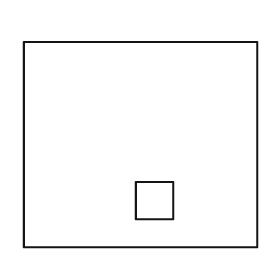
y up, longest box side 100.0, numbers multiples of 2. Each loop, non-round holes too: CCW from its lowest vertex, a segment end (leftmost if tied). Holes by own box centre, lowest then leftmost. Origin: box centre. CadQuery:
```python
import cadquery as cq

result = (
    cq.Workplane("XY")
    .moveTo(-50.0, -44.0)
    .lineTo(50.0, -44.0)
    .lineTo(50.0, 44.0)
    .lineTo(-50.0, 44.0)
    .close()
    .moveTo(-2.0, -32.0)
    .lineTo(14.0, -32.0)
    .lineTo(14.0, -16.0)
    .lineTo(-2.0, -16.0)
    .close()
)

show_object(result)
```